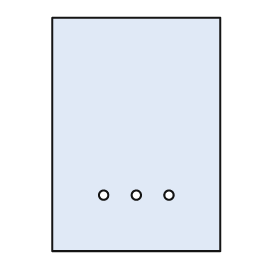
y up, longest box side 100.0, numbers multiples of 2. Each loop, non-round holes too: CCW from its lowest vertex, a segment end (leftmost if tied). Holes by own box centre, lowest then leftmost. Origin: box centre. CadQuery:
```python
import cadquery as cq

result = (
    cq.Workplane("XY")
    .moveTo(-36.0, -50.0)
    .lineTo(36.0, -50.0)
    .lineTo(36.0, 50.0)
    .lineTo(-36.0, 50.0)
    .close()
    .moveTo(-14.0, -26.0)
    .circle(2.0)
    .moveTo(0.0, -26.0)
    .circle(2.0)
    .moveTo(14.0, -26.0)
    .circle(2.0)
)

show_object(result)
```